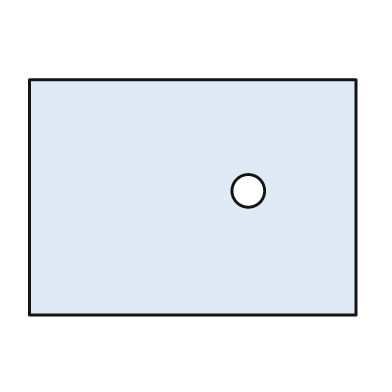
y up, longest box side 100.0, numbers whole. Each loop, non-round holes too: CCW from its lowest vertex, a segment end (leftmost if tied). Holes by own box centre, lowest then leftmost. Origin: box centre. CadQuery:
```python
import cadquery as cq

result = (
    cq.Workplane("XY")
    .moveTo(-50.0, -36.0)
    .lineTo(50.0, -36.0)
    .lineTo(50.0, 36.0)
    .lineTo(-50.0, 36.0)
    .close()
    .moveTo(17.0, 2.0)
    .circle(5.0)
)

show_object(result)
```